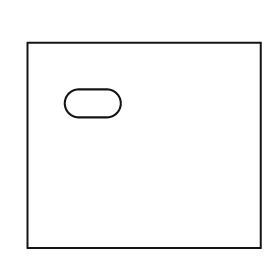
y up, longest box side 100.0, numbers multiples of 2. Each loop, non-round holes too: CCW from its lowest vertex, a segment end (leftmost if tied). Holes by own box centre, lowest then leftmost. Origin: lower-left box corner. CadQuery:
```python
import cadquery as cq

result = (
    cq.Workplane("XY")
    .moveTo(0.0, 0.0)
    .lineTo(100.0, 0.0)
    .lineTo(100.0, 88.0)
    .lineTo(0.0, 88.0)
    .close()
    .moveTo(22.0, 56.0)
    .lineTo(34.0, 56.0)
    .threePointArc((40.0, 62.0), (34.0, 68.0))
    .lineTo(22.0, 68.0)
    .threePointArc((16.0, 62.0), (22.0, 56.0))
    .close()
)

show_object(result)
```